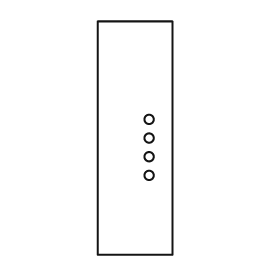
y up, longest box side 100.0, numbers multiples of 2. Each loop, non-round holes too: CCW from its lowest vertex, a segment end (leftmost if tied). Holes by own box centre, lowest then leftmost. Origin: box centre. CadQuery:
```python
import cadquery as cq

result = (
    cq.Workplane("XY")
    .moveTo(-16.0, -50.0)
    .lineTo(16.0, -50.0)
    .lineTo(16.0, 50.0)
    .lineTo(-16.0, 50.0)
    .close()
    .moveTo(6.0, -16.0)
    .circle(2.0)
    .moveTo(6.0, -8.0)
    .circle(2.0)
    .moveTo(6.0, 0.0)
    .circle(2.0)
    .moveTo(6.0, 8.0)
    .circle(2.0)
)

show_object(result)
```